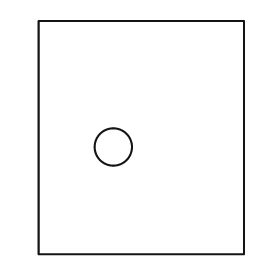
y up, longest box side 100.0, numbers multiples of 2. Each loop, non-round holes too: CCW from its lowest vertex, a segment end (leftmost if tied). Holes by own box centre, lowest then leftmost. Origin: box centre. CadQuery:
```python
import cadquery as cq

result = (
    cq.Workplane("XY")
    .moveTo(-44.0, -50.0)
    .lineTo(44.0, -50.0)
    .lineTo(44.0, 50.0)
    .lineTo(-44.0, 50.0)
    .close()
    .moveTo(-12.0, -4.0)
    .circle(8.0)
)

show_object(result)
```